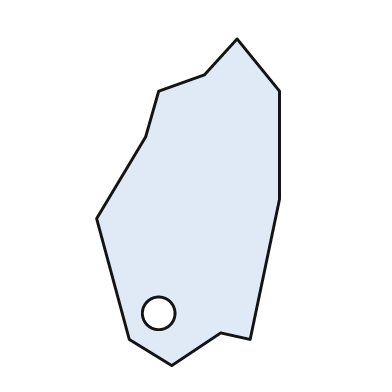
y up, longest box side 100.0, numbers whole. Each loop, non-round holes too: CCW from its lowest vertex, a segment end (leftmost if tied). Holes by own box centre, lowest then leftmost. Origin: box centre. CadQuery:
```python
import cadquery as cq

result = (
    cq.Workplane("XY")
    .moveTo(-5.0, -50.0)
    .lineTo(10.0, -40.0)
    .lineTo(19.0, -42.0)
    .lineTo(28.0, 1.0)
    .lineTo(28.0, 34.0)
    .lineTo(15.0, 50.0)
    .lineTo(5.0, 39.0)
    .lineTo(-9.0, 34.0)
    .lineTo(-13.0, 20.0)
    .lineTo(-28.0, -5.0)
    .lineTo(-18.0, -42.0)
    .close()
    .moveTo(-9.0, -34.0)
    .circle(5.0)
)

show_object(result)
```